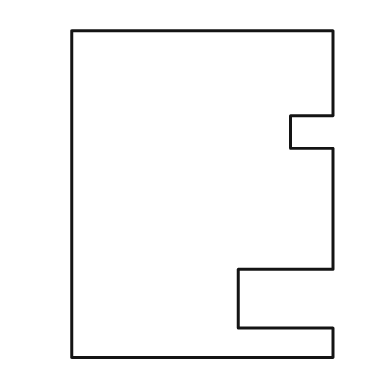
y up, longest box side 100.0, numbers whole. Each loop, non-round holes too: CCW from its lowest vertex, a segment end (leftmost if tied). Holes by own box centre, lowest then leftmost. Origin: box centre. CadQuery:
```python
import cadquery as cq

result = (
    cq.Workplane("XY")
    .moveTo(-40.0, -50.0)
    .lineTo(40.0, -50.0)
    .lineTo(40.0, -41.0)
    .lineTo(11.0, -41.0)
    .lineTo(11.0, -23.0)
    .lineTo(40.0, -23.0)
    .lineTo(40.0, 14.0)
    .lineTo(27.0, 14.0)
    .lineTo(27.0, 24.0)
    .lineTo(40.0, 24.0)
    .lineTo(40.0, 50.0)
    .lineTo(-40.0, 50.0)
    .close()
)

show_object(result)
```